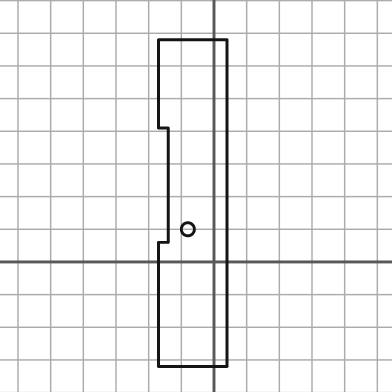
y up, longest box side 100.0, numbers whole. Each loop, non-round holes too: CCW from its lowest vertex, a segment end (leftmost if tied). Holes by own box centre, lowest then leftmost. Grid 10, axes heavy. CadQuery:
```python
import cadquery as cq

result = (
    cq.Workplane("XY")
    .moveTo(-17.0, -32.0)
    .lineTo(4.0, -32.0)
    .lineTo(4.0, 68.0)
    .lineTo(-17.0, 68.0)
    .lineTo(-17.0, 41.0)
    .lineTo(-14.0, 41.0)
    .lineTo(-14.0, 6.0)
    .lineTo(-17.0, 6.0)
    .close()
    .moveTo(-8.0, 10.0)
    .circle(2.0)
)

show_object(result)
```